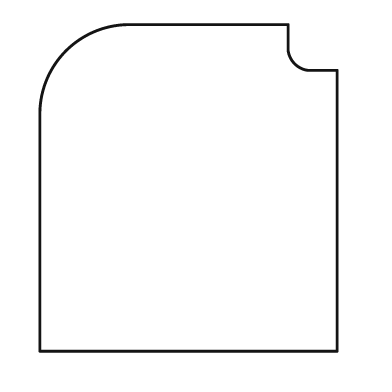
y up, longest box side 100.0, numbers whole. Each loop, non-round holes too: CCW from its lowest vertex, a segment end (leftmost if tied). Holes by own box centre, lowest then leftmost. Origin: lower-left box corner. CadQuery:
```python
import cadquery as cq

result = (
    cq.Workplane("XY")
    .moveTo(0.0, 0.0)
    .lineTo(91.0, 0.0)
    .lineTo(91.0, 86.0)
    .lineTo(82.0, 86.0)
    .threePointArc((78.0, 88.0), (76.0, 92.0))
    .lineTo(76.0, 100.0)
    .lineTo(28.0, 100.0)
    .threePointArc((8.0, 92.0), (0.0, 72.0))
    .close()
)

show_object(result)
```